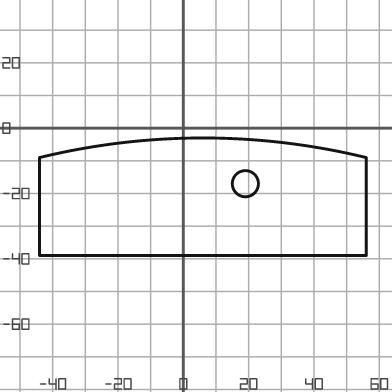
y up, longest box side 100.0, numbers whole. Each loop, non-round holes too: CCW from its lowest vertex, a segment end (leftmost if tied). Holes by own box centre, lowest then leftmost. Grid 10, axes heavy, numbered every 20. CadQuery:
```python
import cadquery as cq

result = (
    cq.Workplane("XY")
    .moveTo(-44.0, -39.0)
    .lineTo(56.0, -39.0)
    .lineTo(56.0, -9.0)
    .threePointArc((6.0, -3.0), (-44.0, -9.0))
    .close()
    .moveTo(19.0, -17.0)
    .circle(4.0)
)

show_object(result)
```